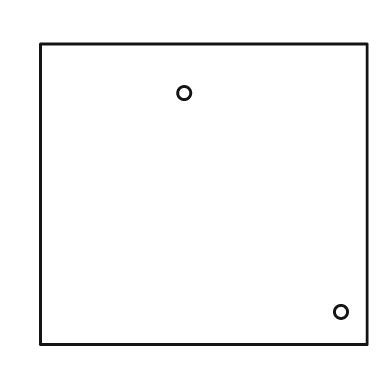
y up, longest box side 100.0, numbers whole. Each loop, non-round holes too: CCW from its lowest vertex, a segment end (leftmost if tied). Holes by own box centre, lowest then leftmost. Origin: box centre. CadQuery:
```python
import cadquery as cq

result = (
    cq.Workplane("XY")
    .moveTo(-50.0, -46.0)
    .lineTo(50.0, -46.0)
    .lineTo(50.0, 46.0)
    .lineTo(-50.0, 46.0)
    .close()
    .moveTo(42.0, -36.0)
    .circle(2.0)
    .moveTo(-6.0, 31.0)
    .circle(2.0)
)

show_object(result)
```